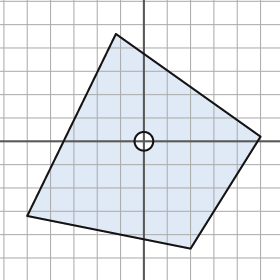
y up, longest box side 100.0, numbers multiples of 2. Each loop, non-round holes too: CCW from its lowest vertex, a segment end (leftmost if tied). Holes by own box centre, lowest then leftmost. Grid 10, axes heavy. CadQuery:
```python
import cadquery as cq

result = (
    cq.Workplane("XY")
    .moveTo(20.0, -46.0)
    .lineTo(50.0, 2.0)
    .lineTo(-12.0, 46.0)
    .lineTo(-50.0, -32.0)
    .close()
    .moveTo(0.0, 0.0)
    .circle(4.0)
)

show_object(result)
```